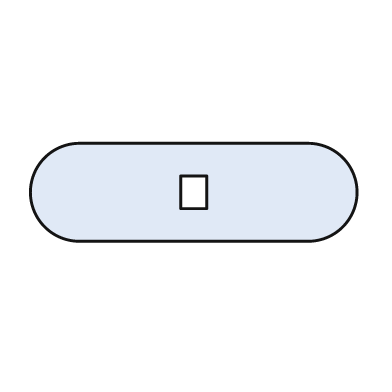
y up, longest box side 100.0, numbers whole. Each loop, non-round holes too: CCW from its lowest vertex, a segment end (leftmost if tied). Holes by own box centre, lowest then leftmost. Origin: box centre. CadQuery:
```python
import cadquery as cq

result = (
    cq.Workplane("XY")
    .moveTo(-35.0, -15.0)
    .lineTo(35.0, -15.0)
    .threePointArc((50.0, 0.0), (35.0, 15.0))
    .lineTo(-35.0, 15.0)
    .threePointArc((-50.0, 0.0), (-35.0, -15.0))
    .close()
    .moveTo(-4.0, -5.0)
    .lineTo(4.0, -5.0)
    .lineTo(4.0, 5.0)
    .lineTo(-4.0, 5.0)
    .close()
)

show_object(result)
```